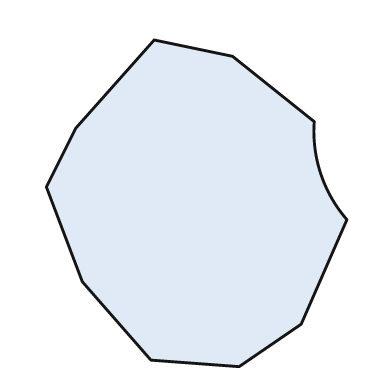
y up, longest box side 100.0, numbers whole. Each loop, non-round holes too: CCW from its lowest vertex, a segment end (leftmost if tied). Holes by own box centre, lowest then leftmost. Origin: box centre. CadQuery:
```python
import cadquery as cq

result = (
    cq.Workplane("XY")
    .moveTo(13.0, -50.0)
    .lineTo(32.0, -37.0)
    .lineTo(46.0, -5.0)
    .threePointArc((38.0, 9.0), (36.0, 25.0))
    .lineTo(11.0, 45.0)
    .lineTo(-13.0, 50.0)
    .lineTo(-37.0, 23.0)
    .lineTo(-46.0, 5.0)
    .lineTo(-35.0, -24.0)
    .lineTo(-14.0, -48.0)
    .close()
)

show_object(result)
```